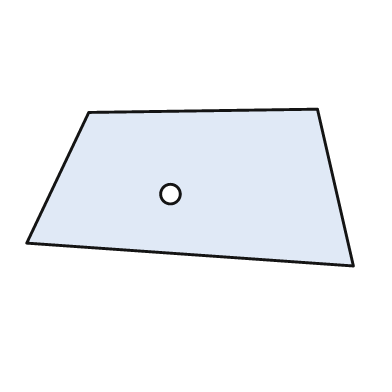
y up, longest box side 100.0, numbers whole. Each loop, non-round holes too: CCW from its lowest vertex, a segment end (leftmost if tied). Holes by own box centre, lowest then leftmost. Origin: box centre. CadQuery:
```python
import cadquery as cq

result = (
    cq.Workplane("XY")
    .moveTo(50.0, -24.0)
    .lineTo(39.0, 24.0)
    .lineTo(-31.0, 23.0)
    .lineTo(-50.0, -17.0)
    .close()
    .moveTo(-6.0, -2.0)
    .circle(3.0)
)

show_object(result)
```